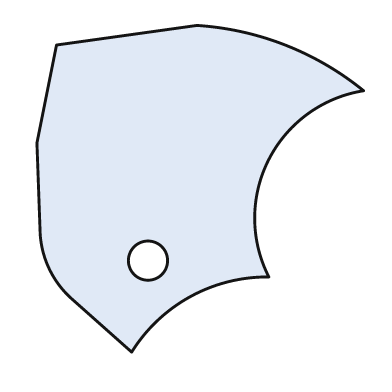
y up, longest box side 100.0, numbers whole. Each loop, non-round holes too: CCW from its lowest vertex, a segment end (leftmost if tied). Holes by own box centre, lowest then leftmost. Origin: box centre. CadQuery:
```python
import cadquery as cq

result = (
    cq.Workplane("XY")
    .moveTo(-21.0, -50.0)
    .threePointArc((-3.0, -33.0), (21.0, -27.0))
    .threePointArc((21.0, 9.0), (50.0, 30.0))
    .threePointArc((26.0, 44.0), (-1.0, 50.0))
    .lineTo(-44.0, 44.0)
    .lineTo(-50.0, 14.0)
    .lineTo(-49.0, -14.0)
    .threePointArc((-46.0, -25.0), (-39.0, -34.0))
    .close()
    .moveTo(-16.0, -22.0)
    .circle(6.0)
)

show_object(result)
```